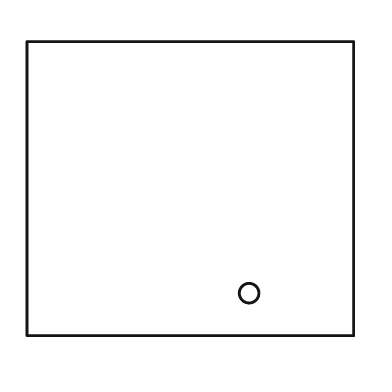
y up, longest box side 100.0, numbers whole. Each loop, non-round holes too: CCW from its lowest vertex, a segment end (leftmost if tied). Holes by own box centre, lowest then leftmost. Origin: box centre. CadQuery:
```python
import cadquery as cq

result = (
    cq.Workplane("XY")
    .moveTo(-50.0, -45.0)
    .lineTo(50.0, -45.0)
    .lineTo(50.0, 45.0)
    .lineTo(-50.0, 45.0)
    .close()
    .moveTo(18.0, -32.0)
    .circle(3.0)
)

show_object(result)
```